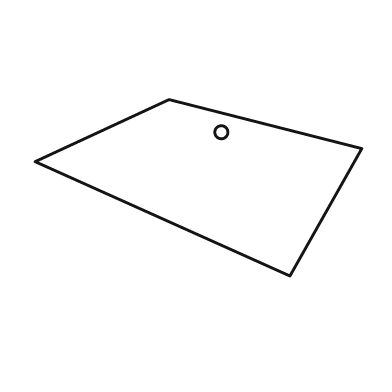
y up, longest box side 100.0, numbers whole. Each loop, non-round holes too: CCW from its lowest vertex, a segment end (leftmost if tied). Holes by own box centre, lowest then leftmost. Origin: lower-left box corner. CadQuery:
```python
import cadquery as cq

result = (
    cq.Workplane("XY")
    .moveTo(78.0, 0.0)
    .lineTo(100.0, 39.0)
    .lineTo(41.0, 54.0)
    .lineTo(0.0, 35.0)
    .close()
    .moveTo(57.0, 44.0)
    .circle(2.0)
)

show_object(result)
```